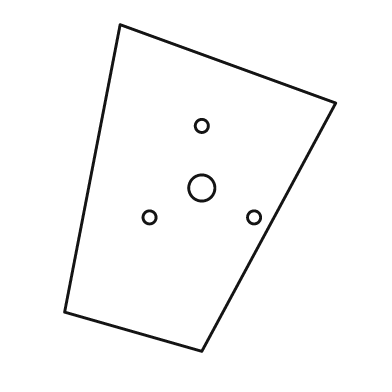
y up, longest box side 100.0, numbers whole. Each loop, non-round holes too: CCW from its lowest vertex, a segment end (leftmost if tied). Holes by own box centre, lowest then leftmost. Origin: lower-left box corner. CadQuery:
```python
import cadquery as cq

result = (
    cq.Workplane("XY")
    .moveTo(42.0, 0.0)
    .lineTo(83.0, 76.0)
    .lineTo(17.0, 100.0)
    .lineTo(0.0, 12.0)
    .close()
    .moveTo(26.0, 41.0)
    .circle(2.0)
    .moveTo(58.0, 41.0)
    .circle(2.0)
    .moveTo(42.0, 50.0)
    .circle(4.0)
    .moveTo(42.0, 69.0)
    .circle(2.0)
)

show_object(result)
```